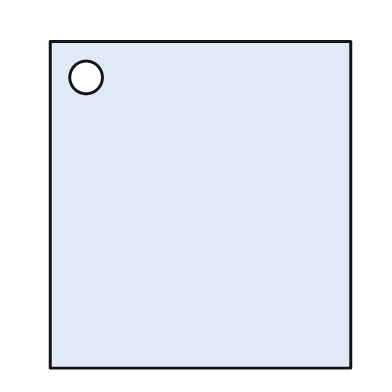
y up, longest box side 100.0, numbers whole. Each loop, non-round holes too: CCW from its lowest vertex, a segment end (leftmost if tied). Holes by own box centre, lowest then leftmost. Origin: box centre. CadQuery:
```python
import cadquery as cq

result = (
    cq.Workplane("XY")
    .moveTo(-46.0, -50.0)
    .lineTo(46.0, -50.0)
    .lineTo(46.0, 50.0)
    .lineTo(-46.0, 50.0)
    .close()
    .moveTo(-35.0, 39.0)
    .circle(5.0)
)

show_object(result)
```